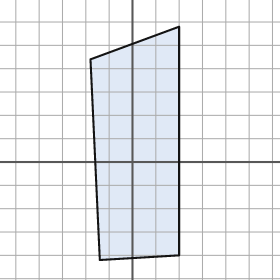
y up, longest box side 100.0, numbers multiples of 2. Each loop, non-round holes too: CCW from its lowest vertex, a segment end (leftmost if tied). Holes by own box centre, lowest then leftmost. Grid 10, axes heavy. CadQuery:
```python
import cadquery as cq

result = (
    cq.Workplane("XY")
    .moveTo(-14.0, -42.0)
    .lineTo(20.0, -40.0)
    .lineTo(20.0, 58.0)
    .lineTo(-18.0, 44.0)
    .close()
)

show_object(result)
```